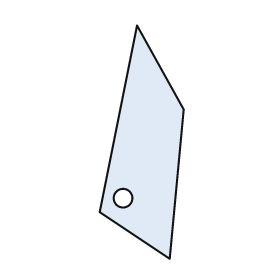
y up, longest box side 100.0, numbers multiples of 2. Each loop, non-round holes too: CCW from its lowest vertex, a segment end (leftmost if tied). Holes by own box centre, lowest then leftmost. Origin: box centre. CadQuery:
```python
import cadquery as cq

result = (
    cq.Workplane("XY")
    .moveTo(12.0, -50.0)
    .lineTo(18.0, 14.0)
    .lineTo(-2.0, 50.0)
    .lineTo(-18.0, -30.0)
    .close()
    .moveTo(-8.0, -24.0)
    .circle(4.0)
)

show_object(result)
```